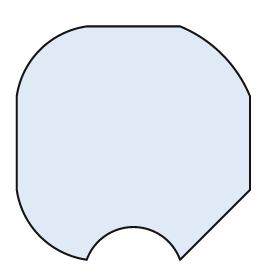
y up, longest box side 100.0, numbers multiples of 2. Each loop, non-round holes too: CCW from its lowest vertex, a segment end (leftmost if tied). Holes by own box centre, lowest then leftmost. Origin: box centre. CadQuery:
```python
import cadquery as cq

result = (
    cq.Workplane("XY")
    .moveTo(-20.0, -50.0)
    .threePointArc((0.0, -36.0), (20.0, -50.0))
    .lineTo(50.0, -20.0)
    .lineTo(50.0, 20.0)
    .threePointArc((38.0, 38.0), (20.0, 50.0))
    .lineTo(-20.0, 50.0)
    .threePointArc((-40.0, 40.0), (-50.0, 20.0))
    .lineTo(-50.0, -20.0)
    .threePointArc((-40.0, -40.0), (-20.0, -50.0))
    .close()
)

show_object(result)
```